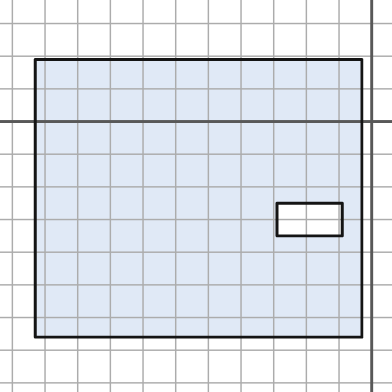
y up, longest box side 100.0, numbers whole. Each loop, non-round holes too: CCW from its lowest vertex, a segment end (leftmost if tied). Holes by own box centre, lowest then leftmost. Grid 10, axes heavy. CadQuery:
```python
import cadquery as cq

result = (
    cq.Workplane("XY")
    .moveTo(-103.0, -66.0)
    .lineTo(-3.0, -66.0)
    .lineTo(-3.0, 19.0)
    .lineTo(-103.0, 19.0)
    .close()
    .moveTo(-29.0, -35.0)
    .lineTo(-9.0, -35.0)
    .lineTo(-9.0, -25.0)
    .lineTo(-29.0, -25.0)
    .close()
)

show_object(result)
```